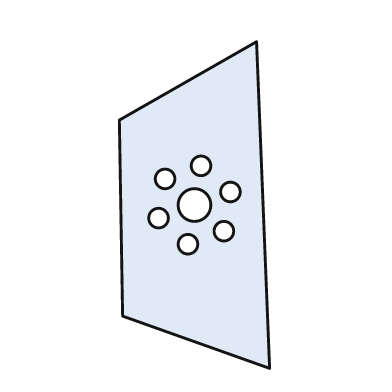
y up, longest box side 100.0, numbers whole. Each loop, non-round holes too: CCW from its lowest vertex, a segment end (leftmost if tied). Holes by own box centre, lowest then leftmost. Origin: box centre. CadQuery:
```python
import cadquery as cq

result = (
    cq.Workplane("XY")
    .moveTo(23.0, -50.0)
    .lineTo(19.0, 50.0)
    .lineTo(-23.0, 26.0)
    .lineTo(-22.0, -34.0)
    .close()
    .moveTo(-2.0, -12.0)
    .circle(3.0)
    .moveTo(9.0, -8.0)
    .circle(3.0)
    .moveTo(-11.0, -4.0)
    .circle(3.0)
    .moveTo(0.0, 0.0)
    .circle(5.0)
    .moveTo(11.0, 4.0)
    .circle(3.0)
    .moveTo(-9.0, 8.0)
    .circle(3.0)
    .moveTo(2.0, 12.0)
    .circle(3.0)
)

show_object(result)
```